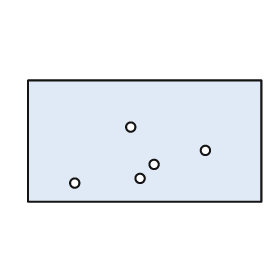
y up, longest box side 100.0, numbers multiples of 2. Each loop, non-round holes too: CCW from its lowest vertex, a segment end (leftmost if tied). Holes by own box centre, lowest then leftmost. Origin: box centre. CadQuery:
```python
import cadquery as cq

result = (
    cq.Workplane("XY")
    .moveTo(-50.0, -26.0)
    .lineTo(50.0, -26.0)
    .lineTo(50.0, 26.0)
    .lineTo(-50.0, 26.0)
    .close()
    .moveTo(-30.0, -18.0)
    .circle(2.0)
    .moveTo(-2.0, -16.0)
    .circle(2.0)
    .moveTo(4.0, -10.0)
    .circle(2.0)
    .moveTo(26.0, -4.0)
    .circle(2.0)
    .moveTo(-6.0, 6.0)
    .circle(2.0)
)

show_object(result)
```